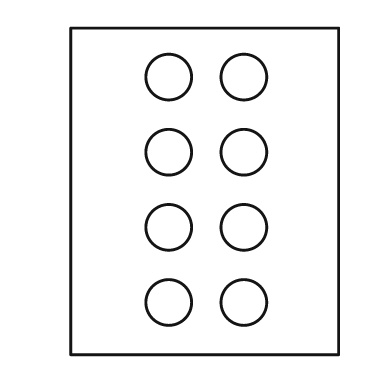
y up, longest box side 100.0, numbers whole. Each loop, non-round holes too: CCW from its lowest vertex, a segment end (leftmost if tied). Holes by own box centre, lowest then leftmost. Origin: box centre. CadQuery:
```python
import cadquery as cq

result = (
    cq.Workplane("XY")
    .moveTo(-41.0, -50.0)
    .lineTo(41.0, -50.0)
    .lineTo(41.0, 50.0)
    .lineTo(-41.0, 50.0)
    .close()
    .moveTo(-11.0, -34.0)
    .circle(7.0)
    .moveTo(12.0, -34.0)
    .circle(7.0)
    .moveTo(-11.0, -11.0)
    .circle(7.0)
    .moveTo(12.0, -11.0)
    .circle(7.0)
    .moveTo(-11.0, 12.0)
    .circle(7.0)
    .moveTo(12.0, 12.0)
    .circle(7.0)
    .moveTo(-11.0, 35.0)
    .circle(7.0)
    .moveTo(12.0, 35.0)
    .circle(7.0)
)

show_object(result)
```